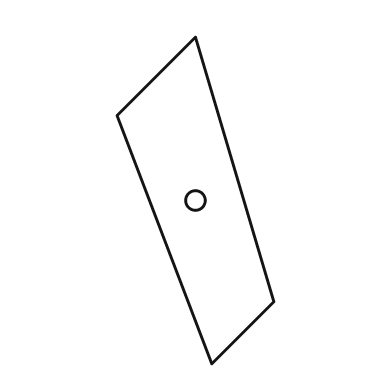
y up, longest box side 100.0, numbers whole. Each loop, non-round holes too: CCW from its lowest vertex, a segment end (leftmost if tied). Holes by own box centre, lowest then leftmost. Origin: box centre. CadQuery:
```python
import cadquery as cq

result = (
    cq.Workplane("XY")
    .moveTo(5.0, -50.0)
    .lineTo(24.0, -31.0)
    .lineTo(0.0, 50.0)
    .lineTo(-24.0, 26.0)
    .close()
    .moveTo(0.0, 0.0)
    .circle(3.0)
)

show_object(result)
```